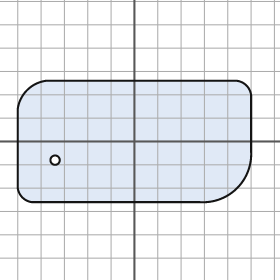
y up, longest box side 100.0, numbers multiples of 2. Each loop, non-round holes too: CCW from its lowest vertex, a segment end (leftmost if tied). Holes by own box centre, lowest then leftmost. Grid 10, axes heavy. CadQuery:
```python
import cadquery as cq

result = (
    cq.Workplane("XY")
    .moveTo(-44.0, -26.0)
    .lineTo(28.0, -26.0)
    .threePointArc((44.0, -20.0), (50.0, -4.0))
    .lineTo(50.0, 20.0)
    .threePointArc((48.0, 24.0), (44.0, 26.0))
    .lineTo(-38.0, 26.0)
    .threePointArc((-46.0, 22.0), (-50.0, 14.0))
    .lineTo(-50.0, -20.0)
    .threePointArc((-48.0, -24.0), (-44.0, -26.0))
    .close()
    .moveTo(-34.0, -8.0)
    .circle(2.0)
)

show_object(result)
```